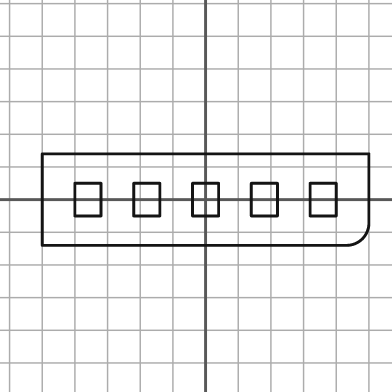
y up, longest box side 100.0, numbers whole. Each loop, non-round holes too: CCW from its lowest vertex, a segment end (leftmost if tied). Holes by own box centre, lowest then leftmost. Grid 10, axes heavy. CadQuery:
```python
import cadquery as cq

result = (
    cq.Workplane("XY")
    .moveTo(-50.0, -14.0)
    .lineTo(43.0, -14.0)
    .threePointArc((48.0, -12.0), (50.0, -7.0))
    .lineTo(50.0, 14.0)
    .lineTo(-50.0, 14.0)
    .close()
    .moveTo(-40.0, -5.0)
    .lineTo(-32.0, -5.0)
    .lineTo(-32.0, 5.0)
    .lineTo(-40.0, 5.0)
    .close()
    .moveTo(-22.0, -5.0)
    .lineTo(-14.0, -5.0)
    .lineTo(-14.0, 5.0)
    .lineTo(-22.0, 5.0)
    .close()
    .moveTo(-4.0, -5.0)
    .lineTo(4.0, -5.0)
    .lineTo(4.0, 5.0)
    .lineTo(-4.0, 5.0)
    .close()
    .moveTo(14.0, -5.0)
    .lineTo(22.0, -5.0)
    .lineTo(22.0, 5.0)
    .lineTo(14.0, 5.0)
    .close()
    .moveTo(32.0, -5.0)
    .lineTo(40.0, -5.0)
    .lineTo(40.0, 5.0)
    .lineTo(32.0, 5.0)
    .close()
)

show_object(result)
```